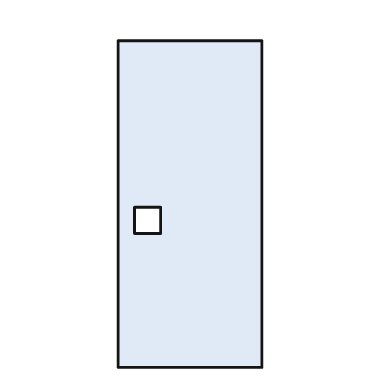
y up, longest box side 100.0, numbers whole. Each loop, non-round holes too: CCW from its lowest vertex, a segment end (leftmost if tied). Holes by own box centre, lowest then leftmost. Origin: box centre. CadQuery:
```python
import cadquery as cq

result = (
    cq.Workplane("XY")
    .moveTo(-22.0, -50.0)
    .lineTo(22.0, -50.0)
    .lineTo(22.0, 50.0)
    .lineTo(-22.0, 50.0)
    .close()
    .moveTo(-17.0, -9.0)
    .lineTo(-9.0, -9.0)
    .lineTo(-9.0, -1.0)
    .lineTo(-17.0, -1.0)
    .close()
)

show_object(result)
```